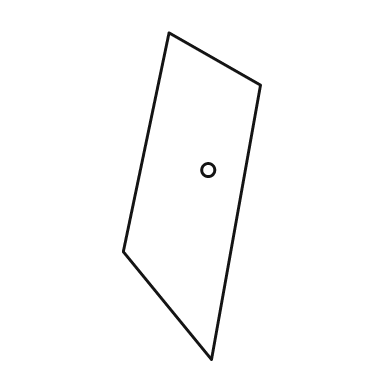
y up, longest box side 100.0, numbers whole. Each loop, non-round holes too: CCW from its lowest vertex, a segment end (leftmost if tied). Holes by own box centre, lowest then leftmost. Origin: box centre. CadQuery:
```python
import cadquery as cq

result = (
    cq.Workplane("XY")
    .moveTo(6.0, -50.0)
    .lineTo(21.0, 34.0)
    .lineTo(-7.0, 50.0)
    .lineTo(-21.0, -17.0)
    .close()
    .moveTo(5.0, 8.0)
    .circle(2.0)
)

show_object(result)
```